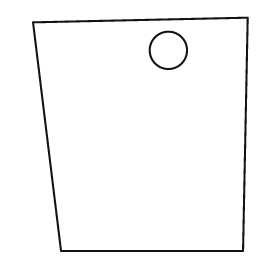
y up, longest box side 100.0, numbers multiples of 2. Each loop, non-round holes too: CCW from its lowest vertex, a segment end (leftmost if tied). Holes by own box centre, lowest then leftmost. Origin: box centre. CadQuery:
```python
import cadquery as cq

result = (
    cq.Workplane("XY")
    .moveTo(-34.0, -50.0)
    .lineTo(44.0, -50.0)
    .lineTo(46.0, 50.0)
    .lineTo(-46.0, 48.0)
    .close()
    .moveTo(12.0, 36.0)
    .circle(8.0)
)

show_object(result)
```